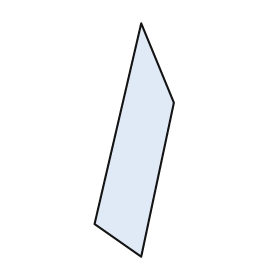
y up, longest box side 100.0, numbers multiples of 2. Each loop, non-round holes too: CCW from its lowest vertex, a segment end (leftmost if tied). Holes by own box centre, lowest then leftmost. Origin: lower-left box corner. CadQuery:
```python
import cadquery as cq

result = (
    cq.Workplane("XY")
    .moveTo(20.0, 0.0)
    .lineTo(34.0, 66.0)
    .lineTo(20.0, 100.0)
    .lineTo(0.0, 14.0)
    .close()
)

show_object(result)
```